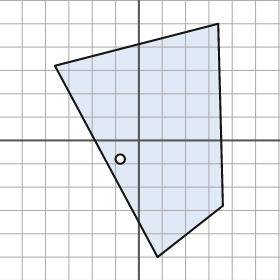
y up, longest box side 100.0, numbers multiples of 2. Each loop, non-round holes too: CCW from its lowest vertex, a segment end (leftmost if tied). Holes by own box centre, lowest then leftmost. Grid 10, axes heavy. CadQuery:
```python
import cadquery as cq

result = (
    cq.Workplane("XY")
    .moveTo(8.0, -50.0)
    .lineTo(36.0, -28.0)
    .lineTo(34.0, 50.0)
    .lineTo(-36.0, 32.0)
    .close()
    .moveTo(-8.0, -8.0)
    .circle(2.0)
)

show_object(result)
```